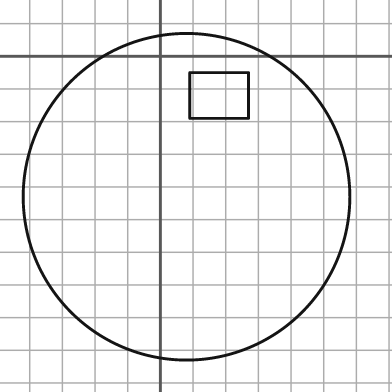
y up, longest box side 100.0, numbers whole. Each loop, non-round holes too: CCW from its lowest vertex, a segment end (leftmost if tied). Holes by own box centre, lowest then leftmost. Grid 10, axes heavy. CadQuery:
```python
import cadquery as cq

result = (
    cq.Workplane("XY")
    .moveTo(8.0, -43.0)
    .circle(50.0)
    .moveTo(9.0, -19.0)
    .lineTo(27.0, -19.0)
    .lineTo(27.0, -5.0)
    .lineTo(9.0, -5.0)
    .close()
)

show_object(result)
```